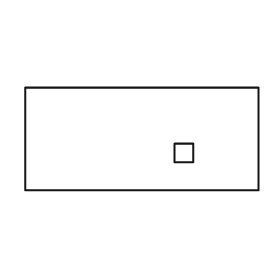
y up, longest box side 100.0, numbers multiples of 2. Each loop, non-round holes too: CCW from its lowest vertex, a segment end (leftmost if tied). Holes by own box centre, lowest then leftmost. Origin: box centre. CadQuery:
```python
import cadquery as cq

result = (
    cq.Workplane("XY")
    .moveTo(-50.0, -22.0)
    .lineTo(50.0, -22.0)
    .lineTo(50.0, 22.0)
    .lineTo(-50.0, 22.0)
    .close()
    .moveTo(14.0, -10.0)
    .lineTo(22.0, -10.0)
    .lineTo(22.0, -2.0)
    .lineTo(14.0, -2.0)
    .close()
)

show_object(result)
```